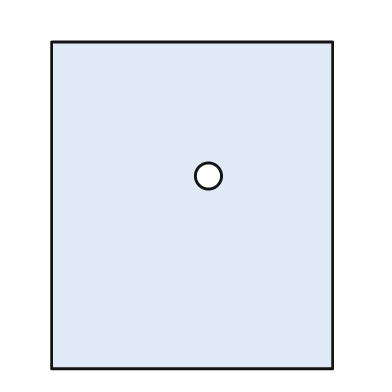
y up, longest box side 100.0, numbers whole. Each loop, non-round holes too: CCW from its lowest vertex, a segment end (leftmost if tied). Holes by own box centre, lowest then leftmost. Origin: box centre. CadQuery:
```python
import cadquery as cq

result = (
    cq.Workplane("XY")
    .moveTo(-43.0, -50.0)
    .lineTo(43.0, -50.0)
    .lineTo(43.0, 50.0)
    .lineTo(-43.0, 50.0)
    .close()
    .moveTo(5.0, 9.0)
    .circle(4.0)
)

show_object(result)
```